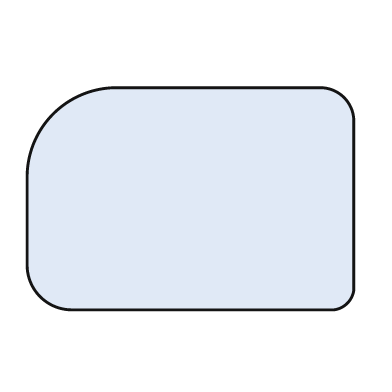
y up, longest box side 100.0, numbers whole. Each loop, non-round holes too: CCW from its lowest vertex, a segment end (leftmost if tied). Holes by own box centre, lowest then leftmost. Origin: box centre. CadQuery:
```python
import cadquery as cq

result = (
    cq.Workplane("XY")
    .moveTo(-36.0, -34.0)
    .lineTo(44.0, -34.0)
    .threePointArc((48.0, -32.0), (50.0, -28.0))
    .lineTo(50.0, 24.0)
    .threePointArc((47.0, 31.0), (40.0, 34.0))
    .lineTo(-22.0, 34.0)
    .threePointArc((-42.0, 26.0), (-50.0, 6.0))
    .lineTo(-50.0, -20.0)
    .threePointArc((-46.0, -30.0), (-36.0, -34.0))
    .close()
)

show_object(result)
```